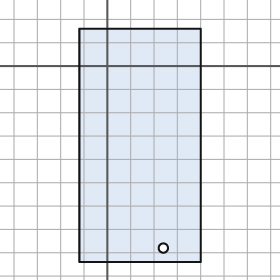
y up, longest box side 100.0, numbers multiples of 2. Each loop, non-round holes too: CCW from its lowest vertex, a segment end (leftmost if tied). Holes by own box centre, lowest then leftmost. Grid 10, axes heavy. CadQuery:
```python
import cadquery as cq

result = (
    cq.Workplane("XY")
    .moveTo(-12.0, -84.0)
    .lineTo(40.0, -84.0)
    .lineTo(40.0, 16.0)
    .lineTo(-12.0, 16.0)
    .close()
    .moveTo(24.0, -78.0)
    .circle(2.0)
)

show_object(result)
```